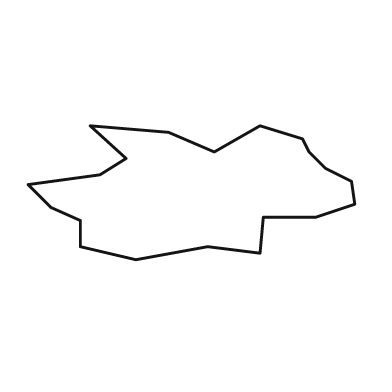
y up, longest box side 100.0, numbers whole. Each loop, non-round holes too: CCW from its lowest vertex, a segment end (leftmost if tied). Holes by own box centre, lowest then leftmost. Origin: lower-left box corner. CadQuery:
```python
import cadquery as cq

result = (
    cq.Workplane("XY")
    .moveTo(33.0, 0.0)
    .lineTo(55.0, 4.0)
    .lineTo(71.0, 2.0)
    .lineTo(72.0, 13.0)
    .lineTo(88.0, 13.0)
    .lineTo(100.0, 17.0)
    .lineTo(99.0, 24.0)
    .lineTo(91.0, 28.0)
    .lineTo(86.0, 33.0)
    .lineTo(84.0, 37.0)
    .lineTo(71.0, 41.0)
    .lineTo(57.0, 33.0)
    .lineTo(43.0, 39.0)
    .lineTo(19.0, 41.0)
    .lineTo(30.0, 31.0)
    .lineTo(22.0, 26.0)
    .lineTo(0.0, 23.0)
    .lineTo(7.0, 16.0)
    .lineTo(16.0, 12.0)
    .lineTo(16.0, 4.0)
    .close()
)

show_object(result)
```